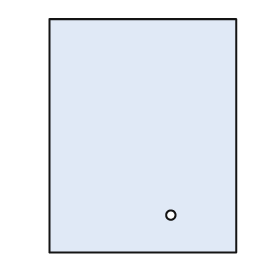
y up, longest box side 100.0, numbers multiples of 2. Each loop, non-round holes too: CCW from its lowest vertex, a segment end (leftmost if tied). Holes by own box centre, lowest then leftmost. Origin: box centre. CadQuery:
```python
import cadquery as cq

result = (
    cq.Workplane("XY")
    .moveTo(-40.0, -50.0)
    .lineTo(40.0, -50.0)
    .lineTo(40.0, 50.0)
    .lineTo(-40.0, 50.0)
    .close()
    .moveTo(12.0, -34.0)
    .circle(2.0)
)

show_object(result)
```